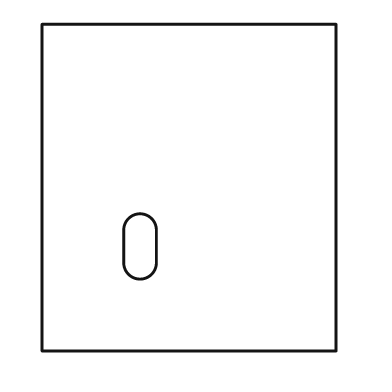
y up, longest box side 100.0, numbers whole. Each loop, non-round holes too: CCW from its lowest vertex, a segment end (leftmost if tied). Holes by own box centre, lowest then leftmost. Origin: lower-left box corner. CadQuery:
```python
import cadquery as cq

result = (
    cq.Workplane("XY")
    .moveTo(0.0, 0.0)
    .lineTo(90.0, 0.0)
    .lineTo(90.0, 100.0)
    .lineTo(0.0, 100.0)
    .close()
    .moveTo(25.0, 27.0)
    .threePointArc((30.0, 22.0), (35.0, 27.0))
    .lineTo(35.0, 37.0)
    .threePointArc((30.0, 42.0), (25.0, 37.0))
    .close()
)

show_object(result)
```